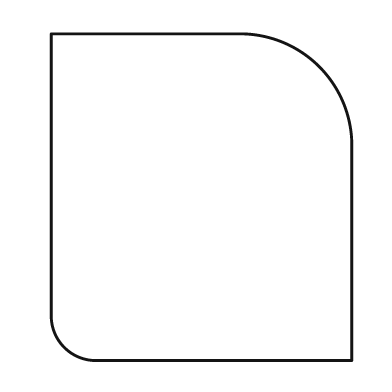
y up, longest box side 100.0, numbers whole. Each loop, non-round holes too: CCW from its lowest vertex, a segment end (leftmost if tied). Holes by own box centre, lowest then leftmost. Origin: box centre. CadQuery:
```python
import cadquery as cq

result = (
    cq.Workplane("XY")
    .moveTo(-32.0, -50.0)
    .lineTo(46.0, -50.0)
    .lineTo(46.0, 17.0)
    .threePointArc((36.0, 40.0), (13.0, 50.0))
    .lineTo(-46.0, 50.0)
    .lineTo(-46.0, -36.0)
    .threePointArc((-42.0, -46.0), (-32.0, -50.0))
    .close()
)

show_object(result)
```